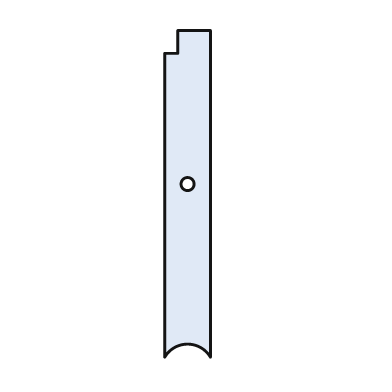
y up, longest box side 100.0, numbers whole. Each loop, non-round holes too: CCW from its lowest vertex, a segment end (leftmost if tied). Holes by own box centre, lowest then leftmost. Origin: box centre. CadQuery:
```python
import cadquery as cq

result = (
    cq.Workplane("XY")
    .moveTo(-7.0, -50.0)
    .threePointArc((0.0, -46.0), (7.0, -50.0))
    .lineTo(7.0, 50.0)
    .lineTo(-3.0, 50.0)
    .lineTo(-3.0, 43.0)
    .lineTo(-7.0, 43.0)
    .close()
    .moveTo(0.0, 3.0)
    .circle(2.0)
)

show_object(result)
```